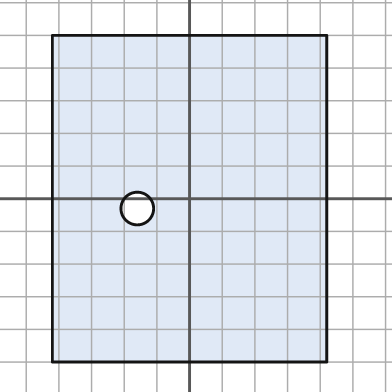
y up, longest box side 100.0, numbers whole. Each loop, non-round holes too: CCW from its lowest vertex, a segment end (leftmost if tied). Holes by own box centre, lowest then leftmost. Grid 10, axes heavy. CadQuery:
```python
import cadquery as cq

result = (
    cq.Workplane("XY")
    .moveTo(-42.0, -50.0)
    .lineTo(42.0, -50.0)
    .lineTo(42.0, 50.0)
    .lineTo(-42.0, 50.0)
    .close()
    .moveTo(-16.0, -3.0)
    .circle(5.0)
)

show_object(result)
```